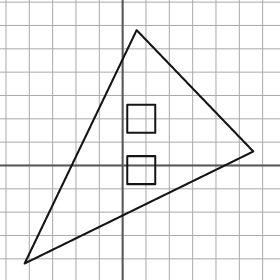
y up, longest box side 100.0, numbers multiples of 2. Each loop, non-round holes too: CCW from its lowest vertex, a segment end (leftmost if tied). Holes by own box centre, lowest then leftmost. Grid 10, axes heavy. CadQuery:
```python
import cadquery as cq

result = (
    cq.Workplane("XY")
    .moveTo(-42.0, -42.0)
    .lineTo(56.0, 6.0)
    .lineTo(6.0, 58.0)
    .close()
    .moveTo(2.0, -8.0)
    .lineTo(14.0, -8.0)
    .lineTo(14.0, 4.0)
    .lineTo(2.0, 4.0)
    .close()
    .moveTo(2.0, 14.0)
    .lineTo(14.0, 14.0)
    .lineTo(14.0, 26.0)
    .lineTo(2.0, 26.0)
    .close()
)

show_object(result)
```